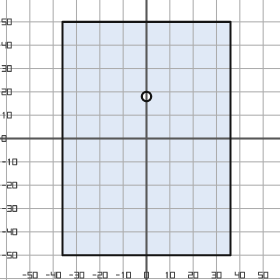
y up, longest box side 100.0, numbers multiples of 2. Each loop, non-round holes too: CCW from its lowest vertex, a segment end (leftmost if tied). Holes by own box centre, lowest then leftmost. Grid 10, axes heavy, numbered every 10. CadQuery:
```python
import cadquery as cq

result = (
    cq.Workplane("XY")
    .moveTo(-36.0, -50.0)
    .lineTo(36.0, -50.0)
    .lineTo(36.0, 50.0)
    .lineTo(-36.0, 50.0)
    .close()
    .moveTo(0.0, 18.0)
    .circle(2.0)
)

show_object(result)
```